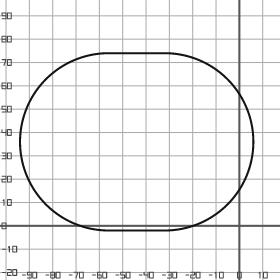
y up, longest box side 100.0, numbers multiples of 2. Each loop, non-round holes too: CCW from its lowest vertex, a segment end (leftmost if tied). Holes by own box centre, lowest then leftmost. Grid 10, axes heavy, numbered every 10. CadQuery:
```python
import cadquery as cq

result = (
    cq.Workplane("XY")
    .moveTo(-56.0, -2.0)
    .lineTo(-32.0, -2.0)
    .threePointArc((6.0, 36.0), (-32.0, 74.0))
    .lineTo(-56.0, 74.0)
    .threePointArc((-94.0, 36.0), (-56.0, -2.0))
    .close()
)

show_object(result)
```